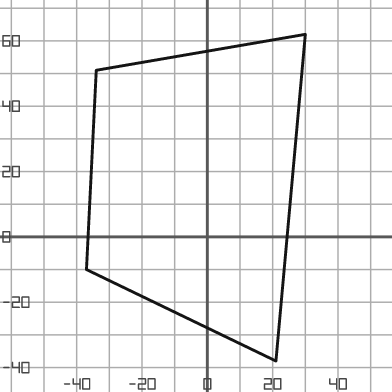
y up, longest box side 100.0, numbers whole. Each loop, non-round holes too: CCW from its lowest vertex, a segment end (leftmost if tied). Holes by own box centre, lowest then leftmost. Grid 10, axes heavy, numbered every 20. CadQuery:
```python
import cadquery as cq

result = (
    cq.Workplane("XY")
    .moveTo(21.0, -38.0)
    .lineTo(30.0, 62.0)
    .lineTo(-34.0, 51.0)
    .lineTo(-37.0, -10.0)
    .close()
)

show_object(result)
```